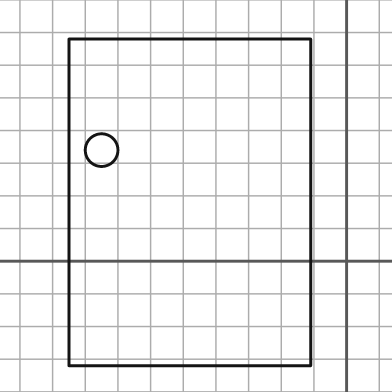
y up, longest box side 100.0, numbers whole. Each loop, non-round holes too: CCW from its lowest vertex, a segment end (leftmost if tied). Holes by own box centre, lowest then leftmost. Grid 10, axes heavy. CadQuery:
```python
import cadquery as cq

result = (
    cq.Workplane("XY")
    .moveTo(-85.0, -32.0)
    .lineTo(-11.0, -32.0)
    .lineTo(-11.0, 68.0)
    .lineTo(-85.0, 68.0)
    .close()
    .moveTo(-75.0, 34.0)
    .circle(5.0)
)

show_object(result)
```